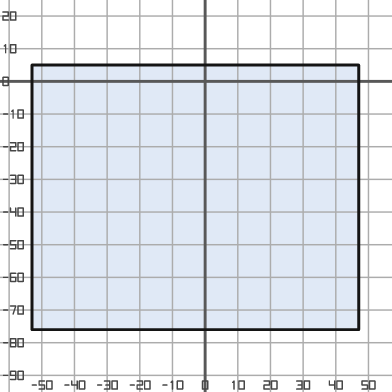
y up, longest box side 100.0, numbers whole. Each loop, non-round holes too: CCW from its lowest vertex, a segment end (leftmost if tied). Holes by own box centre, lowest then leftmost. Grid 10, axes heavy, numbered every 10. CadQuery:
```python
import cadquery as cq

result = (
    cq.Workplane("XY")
    .moveTo(-53.0, -76.0)
    .lineTo(47.0, -76.0)
    .lineTo(47.0, 5.0)
    .lineTo(-53.0, 5.0)
    .close()
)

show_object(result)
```